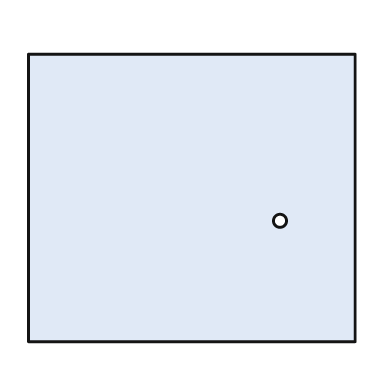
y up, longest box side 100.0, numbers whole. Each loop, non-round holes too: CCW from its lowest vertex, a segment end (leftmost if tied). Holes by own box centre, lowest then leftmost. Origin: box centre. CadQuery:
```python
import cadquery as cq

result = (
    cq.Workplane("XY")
    .moveTo(-50.0, -44.0)
    .lineTo(50.0, -44.0)
    .lineTo(50.0, 44.0)
    .lineTo(-50.0, 44.0)
    .close()
    .moveTo(27.0, -7.0)
    .circle(2.0)
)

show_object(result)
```